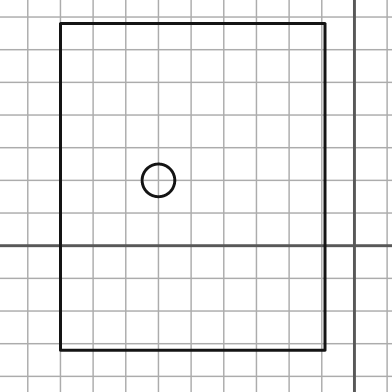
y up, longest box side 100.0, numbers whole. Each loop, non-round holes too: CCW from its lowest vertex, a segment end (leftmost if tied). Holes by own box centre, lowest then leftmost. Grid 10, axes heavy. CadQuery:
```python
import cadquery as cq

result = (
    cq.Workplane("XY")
    .moveTo(-90.0, -32.0)
    .lineTo(-9.0, -32.0)
    .lineTo(-9.0, 68.0)
    .lineTo(-90.0, 68.0)
    .close()
    .moveTo(-60.0, 20.0)
    .circle(5.0)
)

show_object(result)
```